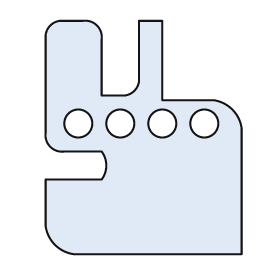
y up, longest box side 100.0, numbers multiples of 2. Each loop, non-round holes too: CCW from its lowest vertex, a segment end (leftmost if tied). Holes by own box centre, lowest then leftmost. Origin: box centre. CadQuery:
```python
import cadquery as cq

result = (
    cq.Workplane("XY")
    .moveTo(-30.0, -50.0)
    .lineTo(42.0, -50.0)
    .lineTo(42.0, 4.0)
    .threePointArc((38.0, 12.0), (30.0, 16.0))
    .lineTo(8.0, 16.0)
    .lineTo(8.0, 50.0)
    .lineTo(-2.0, 50.0)
    .lineTo(-2.0, 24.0)
    .threePointArc((-4.0, 20.0), (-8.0, 18.0))
    .lineTo(-18.0, 18.0)
    .lineTo(-18.0, 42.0)
    .threePointArc((-20.0, 48.0), (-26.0, 50.0))
    .lineTo(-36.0, 50.0)
    .threePointArc((-40.0, 48.0), (-42.0, 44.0))
    .lineTo(-42.0, 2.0)
    .threePointArc((-40.0, -4.0), (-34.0, -6.0))
    .lineTo(-18.0, -6.0)
    .threePointArc((-16.0, -12.0), (-18.0, -18.0))
    .lineTo(-42.0, -18.0)
    .lineTo(-42.0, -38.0)
    .threePointArc((-38.0, -46.0), (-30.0, -50.0))
    .close()
    .moveTo(-28.0, 6.0)
    .circle(6.0)
    .moveTo(-10.0, 6.0)
    .circle(6.0)
    .moveTo(8.0, 6.0)
    .circle(6.0)
    .moveTo(26.0, 6.0)
    .circle(6.0)
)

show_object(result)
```